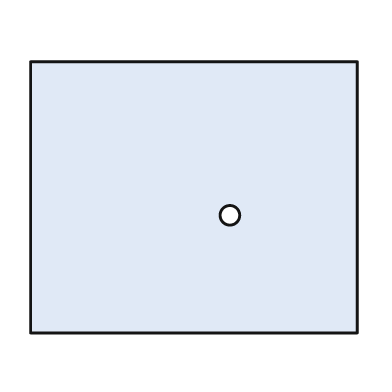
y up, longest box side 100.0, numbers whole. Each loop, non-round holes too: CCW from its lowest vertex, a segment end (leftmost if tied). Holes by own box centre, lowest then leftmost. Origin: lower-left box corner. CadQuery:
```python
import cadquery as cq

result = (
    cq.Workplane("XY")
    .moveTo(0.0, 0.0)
    .lineTo(100.0, 0.0)
    .lineTo(100.0, 83.0)
    .lineTo(0.0, 83.0)
    .close()
    .moveTo(61.0, 36.0)
    .circle(3.0)
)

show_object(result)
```